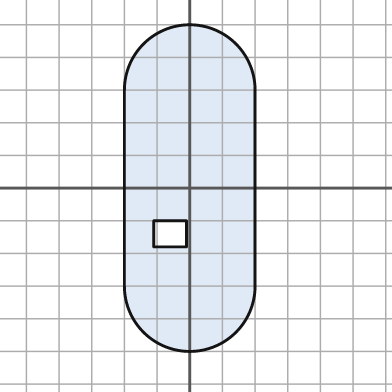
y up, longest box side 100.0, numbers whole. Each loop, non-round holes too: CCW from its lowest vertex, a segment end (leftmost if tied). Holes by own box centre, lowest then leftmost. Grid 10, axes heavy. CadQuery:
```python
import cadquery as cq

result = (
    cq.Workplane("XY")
    .moveTo(-20.0, -30.0)
    .threePointArc((0.0, -50.0), (20.0, -30.0))
    .lineTo(20.0, 30.0)
    .threePointArc((0.0, 50.0), (-20.0, 30.0))
    .close()
    .moveTo(-11.0, -18.0)
    .lineTo(-1.0, -18.0)
    .lineTo(-1.0, -10.0)
    .lineTo(-11.0, -10.0)
    .close()
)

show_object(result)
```